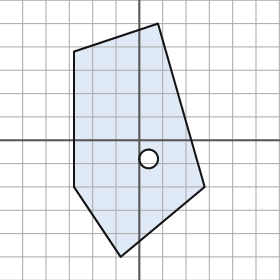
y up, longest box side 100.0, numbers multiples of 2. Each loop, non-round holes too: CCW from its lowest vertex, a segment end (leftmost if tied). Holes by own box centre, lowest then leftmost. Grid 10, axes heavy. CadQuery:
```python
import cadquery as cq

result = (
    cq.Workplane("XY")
    .moveTo(-8.0, -50.0)
    .lineTo(28.0, -20.0)
    .lineTo(8.0, 50.0)
    .lineTo(-28.0, 38.0)
    .lineTo(-28.0, -20.0)
    .close()
    .moveTo(4.0, -8.0)
    .circle(4.0)
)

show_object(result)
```